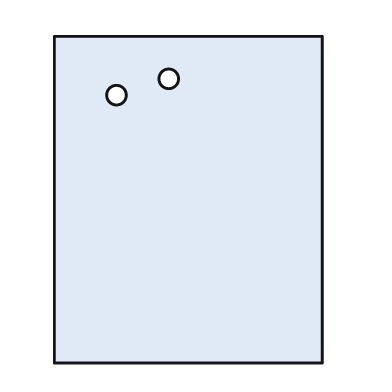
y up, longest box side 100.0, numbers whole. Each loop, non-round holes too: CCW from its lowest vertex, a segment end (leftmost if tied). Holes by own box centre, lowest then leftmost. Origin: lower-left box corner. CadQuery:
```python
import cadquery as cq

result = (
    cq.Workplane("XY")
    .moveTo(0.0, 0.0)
    .lineTo(82.0, 0.0)
    .lineTo(82.0, 100.0)
    .lineTo(0.0, 100.0)
    .close()
    .moveTo(19.0, 82.0)
    .circle(3.0)
    .moveTo(35.0, 87.0)
    .circle(3.0)
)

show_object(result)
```